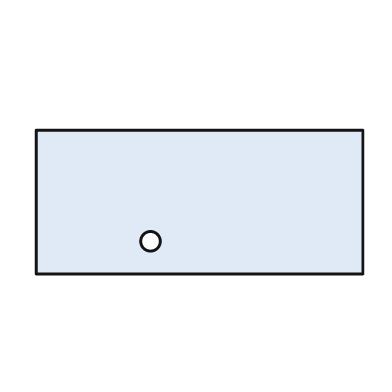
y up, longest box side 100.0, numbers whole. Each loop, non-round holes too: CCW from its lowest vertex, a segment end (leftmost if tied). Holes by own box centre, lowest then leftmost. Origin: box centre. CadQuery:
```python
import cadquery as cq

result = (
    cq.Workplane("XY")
    .moveTo(-50.0, -22.0)
    .lineTo(50.0, -22.0)
    .lineTo(50.0, 22.0)
    .lineTo(-50.0, 22.0)
    .close()
    .moveTo(-15.0, -12.0)
    .circle(3.0)
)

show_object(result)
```